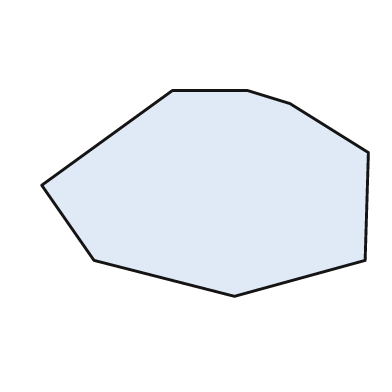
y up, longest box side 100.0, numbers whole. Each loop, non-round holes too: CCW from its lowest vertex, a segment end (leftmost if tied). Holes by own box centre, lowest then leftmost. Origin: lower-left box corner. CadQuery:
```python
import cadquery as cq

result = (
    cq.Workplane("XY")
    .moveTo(59.0, 0.0)
    .lineTo(99.0, 11.0)
    .lineTo(100.0, 44.0)
    .lineTo(76.0, 59.0)
    .lineTo(63.0, 63.0)
    .lineTo(40.0, 63.0)
    .lineTo(0.0, 34.0)
    .lineTo(16.0, 11.0)
    .close()
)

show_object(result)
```